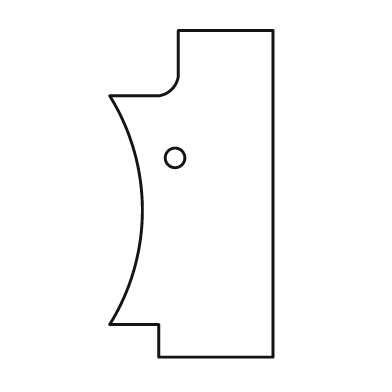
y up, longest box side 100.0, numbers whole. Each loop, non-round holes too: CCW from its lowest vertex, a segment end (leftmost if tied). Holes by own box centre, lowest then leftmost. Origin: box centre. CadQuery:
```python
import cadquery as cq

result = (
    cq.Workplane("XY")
    .moveTo(-10.0, -50.0)
    .lineTo(25.0, -50.0)
    .lineTo(25.0, 50.0)
    .lineTo(-4.0, 50.0)
    .lineTo(-4.0, 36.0)
    .threePointArc((-6.0, 32.0), (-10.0, 30.0))
    .lineTo(-25.0, 30.0)
    .threePointArc((-15.0, -5.0), (-25.0, -40.0))
    .lineTo(-10.0, -40.0)
    .close()
    .moveTo(-5.0, 11.0)
    .circle(3.0)
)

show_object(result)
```